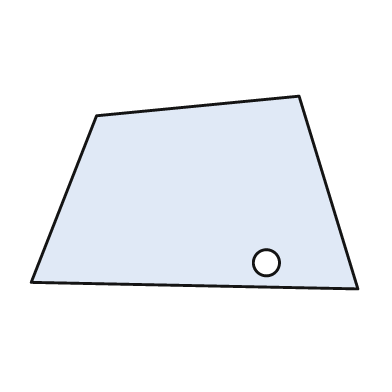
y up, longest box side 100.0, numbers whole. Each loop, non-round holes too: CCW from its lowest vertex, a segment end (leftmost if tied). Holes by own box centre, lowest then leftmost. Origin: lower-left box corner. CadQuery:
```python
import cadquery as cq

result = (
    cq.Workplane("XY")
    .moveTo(100.0, 0.0)
    .lineTo(82.0, 59.0)
    .lineTo(20.0, 53.0)
    .lineTo(0.0, 2.0)
    .close()
    .moveTo(72.0, 8.0)
    .circle(4.0)
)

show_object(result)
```